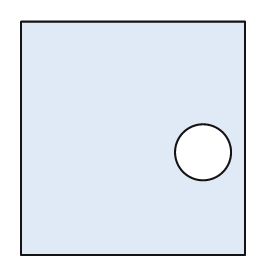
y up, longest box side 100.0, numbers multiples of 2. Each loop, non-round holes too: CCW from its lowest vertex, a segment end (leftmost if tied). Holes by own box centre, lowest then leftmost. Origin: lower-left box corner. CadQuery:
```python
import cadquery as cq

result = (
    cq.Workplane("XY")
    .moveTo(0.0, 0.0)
    .lineTo(96.0, 0.0)
    .lineTo(96.0, 100.0)
    .lineTo(0.0, 100.0)
    .close()
    .moveTo(78.0, 44.0)
    .circle(12.0)
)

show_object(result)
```